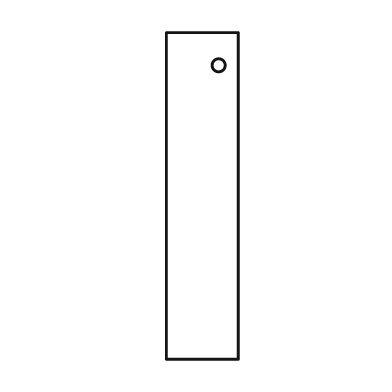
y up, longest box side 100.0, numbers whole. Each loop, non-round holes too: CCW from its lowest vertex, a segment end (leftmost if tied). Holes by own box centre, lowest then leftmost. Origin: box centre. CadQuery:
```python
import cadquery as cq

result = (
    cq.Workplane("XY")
    .moveTo(-11.0, -50.0)
    .lineTo(11.0, -50.0)
    .lineTo(11.0, 50.0)
    .lineTo(-11.0, 50.0)
    .close()
    .moveTo(5.0, 40.0)
    .circle(2.0)
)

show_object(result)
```